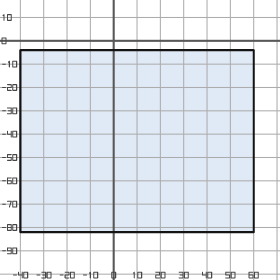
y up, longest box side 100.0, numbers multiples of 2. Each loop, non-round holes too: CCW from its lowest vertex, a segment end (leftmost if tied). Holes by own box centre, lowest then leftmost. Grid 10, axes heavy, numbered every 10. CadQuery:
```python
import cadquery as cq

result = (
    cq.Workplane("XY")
    .moveTo(-40.0, -82.0)
    .lineTo(60.0, -82.0)
    .lineTo(60.0, -4.0)
    .lineTo(-40.0, -4.0)
    .close()
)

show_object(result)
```